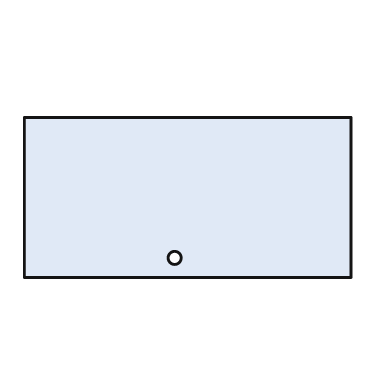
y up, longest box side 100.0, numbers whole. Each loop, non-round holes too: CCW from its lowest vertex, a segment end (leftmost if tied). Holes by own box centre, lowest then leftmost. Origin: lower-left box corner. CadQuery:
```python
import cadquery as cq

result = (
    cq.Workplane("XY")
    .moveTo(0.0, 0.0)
    .lineTo(100.0, 0.0)
    .lineTo(100.0, 49.0)
    .lineTo(0.0, 49.0)
    .close()
    .moveTo(46.0, 6.0)
    .circle(2.0)
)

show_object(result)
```